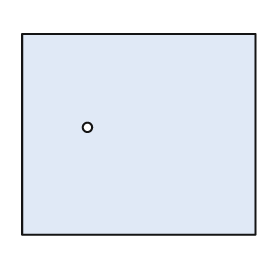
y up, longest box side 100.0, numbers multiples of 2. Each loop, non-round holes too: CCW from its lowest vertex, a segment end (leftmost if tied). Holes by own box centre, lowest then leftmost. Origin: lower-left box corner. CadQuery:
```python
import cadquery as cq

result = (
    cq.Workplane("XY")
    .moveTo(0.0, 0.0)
    .lineTo(100.0, 0.0)
    .lineTo(100.0, 86.0)
    .lineTo(0.0, 86.0)
    .close()
    .moveTo(28.0, 46.0)
    .circle(2.0)
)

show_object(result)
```